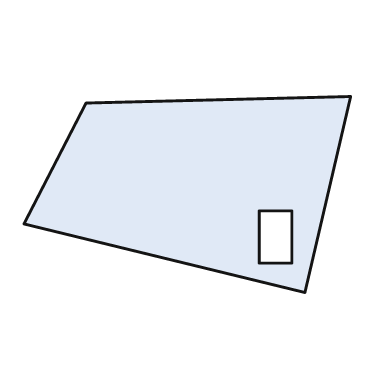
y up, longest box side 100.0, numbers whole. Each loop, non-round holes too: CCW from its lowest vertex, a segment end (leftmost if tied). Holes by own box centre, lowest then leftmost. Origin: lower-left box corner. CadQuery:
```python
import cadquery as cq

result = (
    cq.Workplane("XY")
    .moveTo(86.0, 0.0)
    .lineTo(100.0, 60.0)
    .lineTo(19.0, 58.0)
    .lineTo(0.0, 21.0)
    .close()
    .moveTo(72.0, 9.0)
    .lineTo(82.0, 9.0)
    .lineTo(82.0, 25.0)
    .lineTo(72.0, 25.0)
    .close()
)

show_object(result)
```